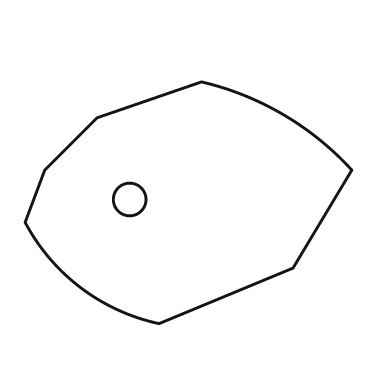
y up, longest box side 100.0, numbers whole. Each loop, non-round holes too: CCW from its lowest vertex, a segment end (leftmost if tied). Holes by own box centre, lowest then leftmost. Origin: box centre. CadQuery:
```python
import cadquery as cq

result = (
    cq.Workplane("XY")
    .moveTo(-9.0, -37.0)
    .lineTo(32.0, -20.0)
    .lineTo(50.0, 10.0)
    .threePointArc((29.0, 27.0), (4.0, 37.0))
    .lineTo(-28.0, 26.0)
    .lineTo(-44.0, 10.0)
    .lineTo(-50.0, -6.0)
    .threePointArc((-33.0, -26.0), (-9.0, -37.0))
    .close()
    .moveTo(-18.0, 1.0)
    .circle(5.0)
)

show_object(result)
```